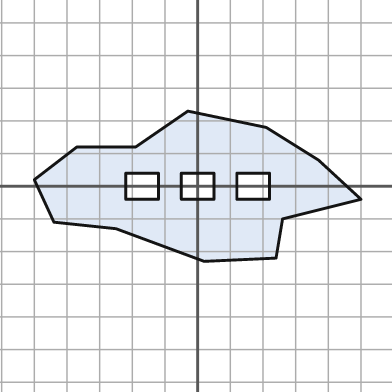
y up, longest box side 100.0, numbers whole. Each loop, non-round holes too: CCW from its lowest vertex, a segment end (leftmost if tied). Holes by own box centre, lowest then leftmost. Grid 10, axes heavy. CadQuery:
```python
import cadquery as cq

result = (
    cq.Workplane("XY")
    .moveTo(2.0, -23.0)
    .lineTo(24.0, -22.0)
    .lineTo(26.0, -10.0)
    .lineTo(50.0, -4.0)
    .lineTo(37.0, 8.0)
    .lineTo(21.0, 18.0)
    .lineTo(-3.0, 23.0)
    .lineTo(-19.0, 12.0)
    .lineTo(-37.0, 12.0)
    .lineTo(-50.0, 2.0)
    .lineTo(-44.0, -11.0)
    .lineTo(-25.0, -13.0)
    .close()
    .moveTo(-22.0, -4.0)
    .lineTo(-12.0, -4.0)
    .lineTo(-12.0, 4.0)
    .lineTo(-22.0, 4.0)
    .close()
    .moveTo(-5.0, -4.0)
    .lineTo(5.0, -4.0)
    .lineTo(5.0, 4.0)
    .lineTo(-5.0, 4.0)
    .close()
    .moveTo(12.0, -4.0)
    .lineTo(22.0, -4.0)
    .lineTo(22.0, 4.0)
    .lineTo(12.0, 4.0)
    .close()
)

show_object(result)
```